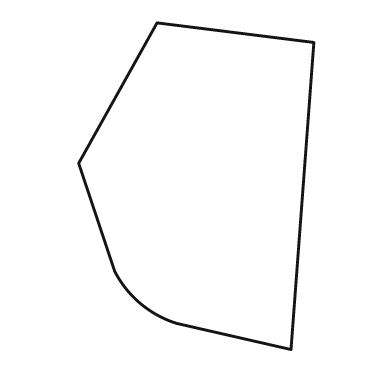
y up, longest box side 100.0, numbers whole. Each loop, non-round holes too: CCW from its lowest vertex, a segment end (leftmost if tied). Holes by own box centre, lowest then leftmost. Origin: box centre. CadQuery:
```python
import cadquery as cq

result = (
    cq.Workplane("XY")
    .moveTo(29.0, -50.0)
    .lineTo(36.0, 44.0)
    .lineTo(-12.0, 50.0)
    .lineTo(-36.0, 7.0)
    .lineTo(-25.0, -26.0)
    .threePointArc((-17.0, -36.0), (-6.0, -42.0))
    .close()
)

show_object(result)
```